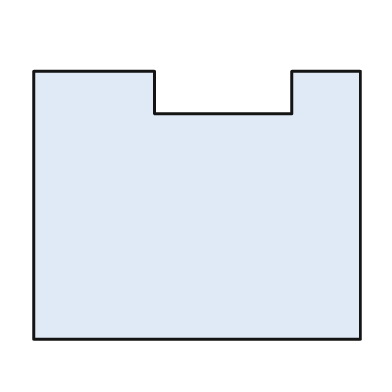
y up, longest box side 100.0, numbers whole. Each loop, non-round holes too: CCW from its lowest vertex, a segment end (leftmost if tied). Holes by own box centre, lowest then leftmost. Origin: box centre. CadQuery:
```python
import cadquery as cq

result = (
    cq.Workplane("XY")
    .moveTo(-50.0, -41.0)
    .lineTo(50.0, -41.0)
    .lineTo(50.0, 41.0)
    .lineTo(29.0, 41.0)
    .lineTo(29.0, 28.0)
    .lineTo(-13.0, 28.0)
    .lineTo(-13.0, 41.0)
    .lineTo(-50.0, 41.0)
    .close()
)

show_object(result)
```